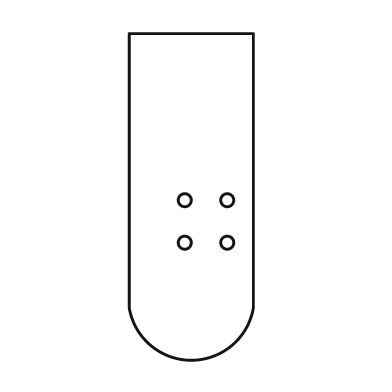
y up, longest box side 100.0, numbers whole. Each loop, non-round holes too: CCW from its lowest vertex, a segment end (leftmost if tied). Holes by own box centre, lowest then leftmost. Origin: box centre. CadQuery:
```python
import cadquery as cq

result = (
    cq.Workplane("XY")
    .moveTo(-19.0, -34.0)
    .threePointArc((0.0, -50.0), (19.0, -34.0))
    .lineTo(19.0, 50.0)
    .lineTo(-19.0, 50.0)
    .close()
    .moveTo(-2.0, -14.0)
    .circle(2.0)
    .moveTo(11.0, -14.0)
    .circle(2.0)
    .moveTo(-2.0, -1.0)
    .circle(2.0)
    .moveTo(11.0, -1.0)
    .circle(2.0)
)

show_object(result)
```